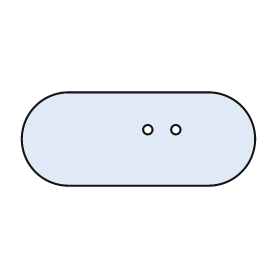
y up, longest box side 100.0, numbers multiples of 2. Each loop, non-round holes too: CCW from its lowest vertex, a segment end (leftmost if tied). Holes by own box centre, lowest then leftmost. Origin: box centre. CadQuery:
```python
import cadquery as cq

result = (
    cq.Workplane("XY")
    .moveTo(-30.0, -20.0)
    .lineTo(30.0, -20.0)
    .threePointArc((50.0, 0.0), (30.0, 20.0))
    .lineTo(-30.0, 20.0)
    .threePointArc((-50.0, 0.0), (-30.0, -20.0))
    .close()
    .moveTo(4.0, 4.0)
    .circle(2.0)
    .moveTo(16.0, 4.0)
    .circle(2.0)
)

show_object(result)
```